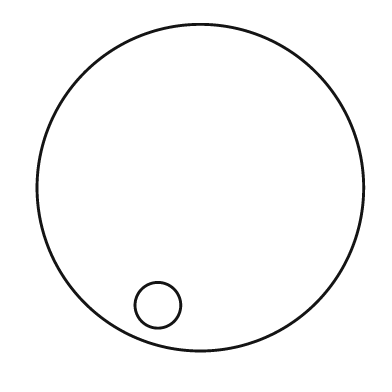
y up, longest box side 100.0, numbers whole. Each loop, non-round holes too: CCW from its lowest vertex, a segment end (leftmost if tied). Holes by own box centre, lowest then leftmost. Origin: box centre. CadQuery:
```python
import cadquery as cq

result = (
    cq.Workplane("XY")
    .moveTo(0.0, 0.0)
    .circle(50.0)
    .moveTo(-13.0, -36.0)
    .circle(7.0)
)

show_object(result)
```